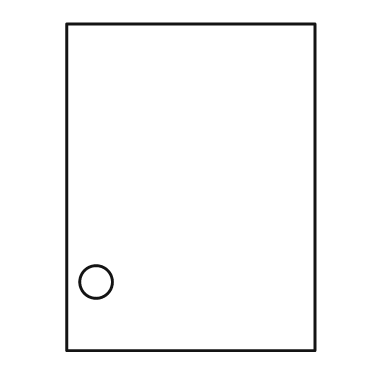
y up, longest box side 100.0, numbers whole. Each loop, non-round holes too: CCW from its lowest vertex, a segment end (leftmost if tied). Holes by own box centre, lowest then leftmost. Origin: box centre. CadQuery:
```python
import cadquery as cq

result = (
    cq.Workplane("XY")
    .moveTo(-38.0, -50.0)
    .lineTo(38.0, -50.0)
    .lineTo(38.0, 50.0)
    .lineTo(-38.0, 50.0)
    .close()
    .moveTo(-29.0, -29.0)
    .circle(5.0)
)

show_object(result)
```